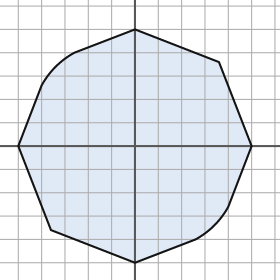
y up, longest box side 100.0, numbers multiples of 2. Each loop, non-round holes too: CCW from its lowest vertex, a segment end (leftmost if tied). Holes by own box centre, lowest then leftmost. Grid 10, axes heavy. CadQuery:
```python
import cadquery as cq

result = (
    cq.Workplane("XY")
    .moveTo(0.0, -50.0)
    .lineTo(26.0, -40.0)
    .threePointArc((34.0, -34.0), (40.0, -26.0))
    .lineTo(50.0, 0.0)
    .lineTo(36.0, 36.0)
    .lineTo(0.0, 50.0)
    .lineTo(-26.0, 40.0)
    .threePointArc((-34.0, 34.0), (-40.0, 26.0))
    .lineTo(-50.0, 0.0)
    .lineTo(-36.0, -36.0)
    .close()
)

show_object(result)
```